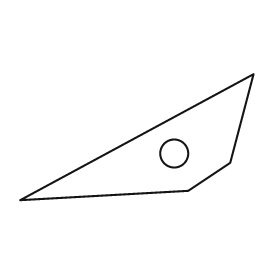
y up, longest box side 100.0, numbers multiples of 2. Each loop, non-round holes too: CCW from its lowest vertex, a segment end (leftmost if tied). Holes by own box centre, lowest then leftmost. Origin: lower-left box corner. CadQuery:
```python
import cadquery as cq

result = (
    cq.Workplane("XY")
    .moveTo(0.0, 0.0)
    .lineTo(72.0, 4.0)
    .lineTo(90.0, 16.0)
    .lineTo(100.0, 54.0)
    .close()
    .moveTo(66.0, 20.0)
    .circle(6.0)
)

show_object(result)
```